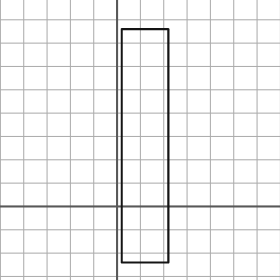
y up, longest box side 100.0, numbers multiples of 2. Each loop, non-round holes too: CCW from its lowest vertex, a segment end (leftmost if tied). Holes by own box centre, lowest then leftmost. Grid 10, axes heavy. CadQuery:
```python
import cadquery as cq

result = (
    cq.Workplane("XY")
    .moveTo(2.0, -24.0)
    .lineTo(22.0, -24.0)
    .lineTo(22.0, 76.0)
    .lineTo(2.0, 76.0)
    .close()
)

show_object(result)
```